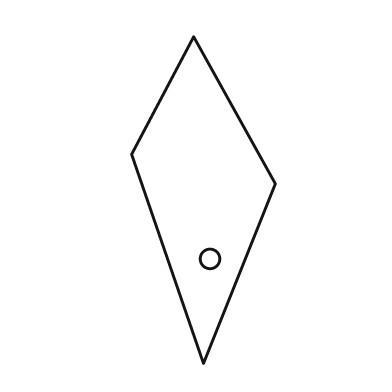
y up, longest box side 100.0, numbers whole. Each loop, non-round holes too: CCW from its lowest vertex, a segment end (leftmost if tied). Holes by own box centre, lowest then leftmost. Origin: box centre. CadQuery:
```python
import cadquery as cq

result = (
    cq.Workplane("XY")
    .moveTo(0.0, -50.0)
    .lineTo(22.0, 5.0)
    .lineTo(-3.0, 50.0)
    .lineTo(-22.0, 14.0)
    .close()
    .moveTo(2.0, -18.0)
    .circle(3.0)
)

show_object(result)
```